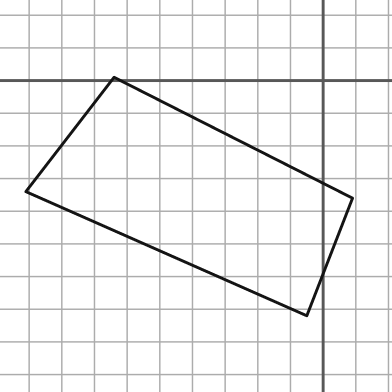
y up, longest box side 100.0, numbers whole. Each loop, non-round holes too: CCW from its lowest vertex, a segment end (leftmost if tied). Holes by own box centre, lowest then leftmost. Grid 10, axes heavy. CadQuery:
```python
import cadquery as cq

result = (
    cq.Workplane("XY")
    .moveTo(-5.0, -72.0)
    .lineTo(9.0, -36.0)
    .lineTo(-64.0, 1.0)
    .lineTo(-91.0, -34.0)
    .close()
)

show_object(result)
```